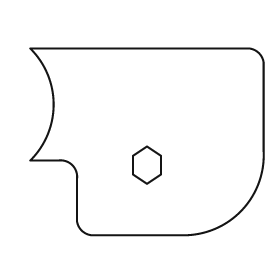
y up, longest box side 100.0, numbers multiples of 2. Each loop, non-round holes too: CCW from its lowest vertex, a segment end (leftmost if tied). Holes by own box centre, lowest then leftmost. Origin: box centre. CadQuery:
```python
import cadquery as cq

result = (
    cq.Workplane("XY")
    .moveTo(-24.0, -40.0)
    .lineTo(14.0, -40.0)
    .threePointArc((40.0, -30.0), (50.0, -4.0))
    .lineTo(50.0, 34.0)
    .threePointArc((48.0, 38.0), (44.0, 40.0))
    .lineTo(-50.0, 40.0)
    .threePointArc((-40.0, 16.0), (-50.0, -8.0))
    .lineTo(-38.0, -8.0)
    .threePointArc((-32.0, -10.0), (-30.0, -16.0))
    .lineTo(-30.0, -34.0)
    .threePointArc((-28.0, -38.0), (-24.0, -40.0))
    .close()
    .moveTo(0.0, -18.0)
    .lineTo(6.0, -14.0)
    .lineTo(6.0, -6.0)
    .lineTo(0.0, -2.0)
    .lineTo(-6.0, -6.0)
    .lineTo(-6.0, -14.0)
    .close()
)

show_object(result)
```